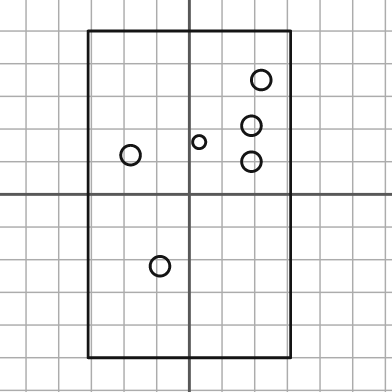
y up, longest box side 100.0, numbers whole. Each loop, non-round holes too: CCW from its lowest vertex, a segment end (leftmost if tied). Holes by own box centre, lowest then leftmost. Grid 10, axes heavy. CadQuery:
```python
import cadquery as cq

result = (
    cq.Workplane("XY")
    .moveTo(-31.0, -50.0)
    .lineTo(31.0, -50.0)
    .lineTo(31.0, 50.0)
    .lineTo(-31.0, 50.0)
    .close()
    .moveTo(-9.0, -22.0)
    .circle(3.0)
    .moveTo(19.0, 10.0)
    .circle(3.0)
    .moveTo(-18.0, 12.0)
    .circle(3.0)
    .moveTo(3.0, 16.0)
    .circle(2.0)
    .moveTo(19.0, 21.0)
    .circle(3.0)
    .moveTo(22.0, 35.0)
    .circle(3.0)
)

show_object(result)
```